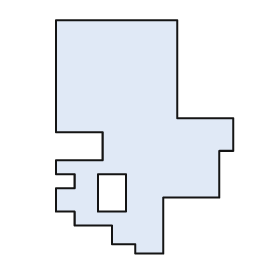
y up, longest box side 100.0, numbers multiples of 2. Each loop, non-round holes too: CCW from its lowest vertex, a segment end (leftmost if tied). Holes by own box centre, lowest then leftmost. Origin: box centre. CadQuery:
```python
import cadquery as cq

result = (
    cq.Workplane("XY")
    .moveTo(-4.0, -50.0)
    .lineTo(8.0, -50.0)
    .lineTo(8.0, -26.0)
    .lineTo(32.0, -26.0)
    .lineTo(32.0, -6.0)
    .lineTo(38.0, -6.0)
    .lineTo(38.0, 8.0)
    .lineTo(14.0, 8.0)
    .lineTo(14.0, 50.0)
    .lineTo(-38.0, 50.0)
    .lineTo(-38.0, 2.0)
    .lineTo(-18.0, 2.0)
    .lineTo(-18.0, -10.0)
    .lineTo(-38.0, -10.0)
    .lineTo(-38.0, -16.0)
    .lineTo(-30.0, -16.0)
    .lineTo(-30.0, -22.0)
    .lineTo(-38.0, -22.0)
    .lineTo(-38.0, -32.0)
    .lineTo(-30.0, -32.0)
    .lineTo(-30.0, -38.0)
    .lineTo(-14.0, -38.0)
    .lineTo(-14.0, -46.0)
    .lineTo(-4.0, -46.0)
    .close()
    .moveTo(-20.0, -32.0)
    .lineTo(-8.0, -32.0)
    .lineTo(-8.0, -16.0)
    .lineTo(-20.0, -16.0)
    .close()
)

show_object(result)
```